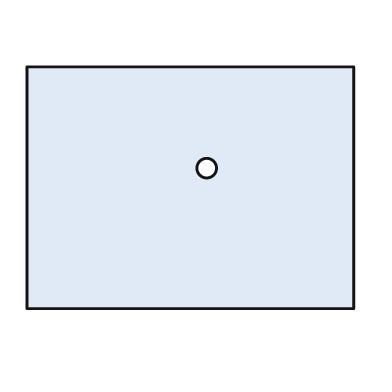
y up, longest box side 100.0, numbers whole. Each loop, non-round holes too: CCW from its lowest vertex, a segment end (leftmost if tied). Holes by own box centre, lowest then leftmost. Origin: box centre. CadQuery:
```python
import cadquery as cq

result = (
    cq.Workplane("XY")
    .moveTo(-50.0, -37.0)
    .lineTo(50.0, -37.0)
    .lineTo(50.0, 37.0)
    .lineTo(-50.0, 37.0)
    .close()
    .moveTo(5.0, 6.0)
    .circle(3.0)
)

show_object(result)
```